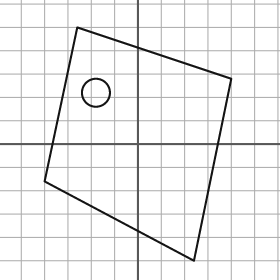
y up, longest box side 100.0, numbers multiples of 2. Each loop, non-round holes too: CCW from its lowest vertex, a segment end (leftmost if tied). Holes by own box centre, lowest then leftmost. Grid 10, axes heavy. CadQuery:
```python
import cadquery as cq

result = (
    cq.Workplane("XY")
    .moveTo(24.0, -50.0)
    .lineTo(40.0, 28.0)
    .lineTo(-26.0, 50.0)
    .lineTo(-40.0, -16.0)
    .close()
    .moveTo(-18.0, 22.0)
    .circle(6.0)
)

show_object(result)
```